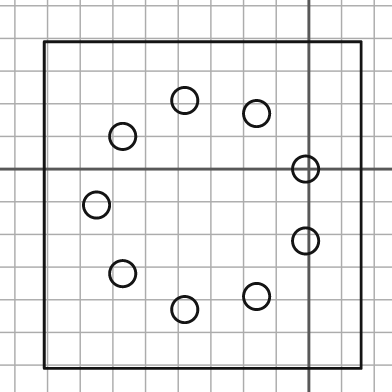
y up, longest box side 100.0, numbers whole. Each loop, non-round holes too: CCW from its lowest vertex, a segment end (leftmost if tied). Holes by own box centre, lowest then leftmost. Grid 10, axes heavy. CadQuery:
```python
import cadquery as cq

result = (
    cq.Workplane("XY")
    .moveTo(-81.0, -61.0)
    .lineTo(16.0, -61.0)
    .lineTo(16.0, 39.0)
    .lineTo(-81.0, 39.0)
    .close()
    .moveTo(-38.0, -43.0)
    .circle(4.0)
    .moveTo(-16.0, -39.0)
    .circle(4.0)
    .moveTo(-57.0, -32.0)
    .circle(4.0)
    .moveTo(-1.0, -22.0)
    .circle(4.0)
    .moveTo(-65.0, -11.0)
    .circle(4.0)
    .moveTo(-1.0, 0.0)
    .circle(4.0)
    .moveTo(-57.0, 10.0)
    .circle(4.0)
    .moveTo(-16.0, 17.0)
    .circle(4.0)
    .moveTo(-38.0, 21.0)
    .circle(4.0)
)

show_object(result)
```